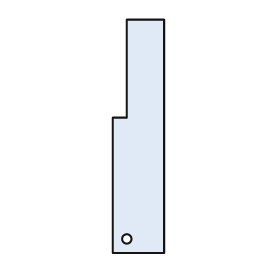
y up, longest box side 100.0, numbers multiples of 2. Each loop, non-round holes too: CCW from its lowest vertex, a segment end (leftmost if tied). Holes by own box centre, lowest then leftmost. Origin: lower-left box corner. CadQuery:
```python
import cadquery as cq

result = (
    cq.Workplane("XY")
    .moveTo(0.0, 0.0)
    .lineTo(22.0, 0.0)
    .lineTo(22.0, 100.0)
    .lineTo(6.0, 100.0)
    .lineTo(6.0, 58.0)
    .lineTo(0.0, 58.0)
    .close()
    .moveTo(6.0, 6.0)
    .circle(2.0)
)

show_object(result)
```